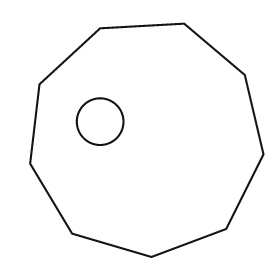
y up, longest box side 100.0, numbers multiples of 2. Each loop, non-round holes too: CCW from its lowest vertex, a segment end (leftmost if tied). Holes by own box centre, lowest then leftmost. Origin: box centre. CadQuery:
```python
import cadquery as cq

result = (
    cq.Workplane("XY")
    .moveTo(2.0, -50.0)
    .lineTo(34.0, -38.0)
    .lineTo(50.0, -6.0)
    .lineTo(42.0, 28.0)
    .lineTo(16.0, 50.0)
    .lineTo(-20.0, 48.0)
    .lineTo(-46.0, 24.0)
    .lineTo(-50.0, -10.0)
    .lineTo(-32.0, -40.0)
    .close()
    .moveTo(-20.0, 8.0)
    .circle(10.0)
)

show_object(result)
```